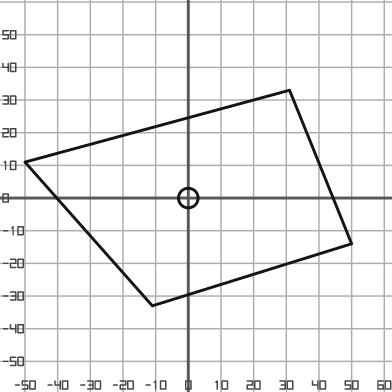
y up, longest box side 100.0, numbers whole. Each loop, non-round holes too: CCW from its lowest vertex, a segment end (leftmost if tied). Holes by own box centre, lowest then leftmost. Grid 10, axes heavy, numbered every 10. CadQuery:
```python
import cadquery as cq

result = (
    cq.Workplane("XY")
    .moveTo(-11.0, -33.0)
    .lineTo(50.0, -14.0)
    .lineTo(31.0, 33.0)
    .lineTo(-50.0, 11.0)
    .close()
    .moveTo(0.0, 0.0)
    .circle(3.0)
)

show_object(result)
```